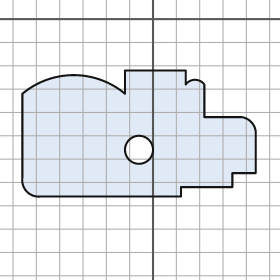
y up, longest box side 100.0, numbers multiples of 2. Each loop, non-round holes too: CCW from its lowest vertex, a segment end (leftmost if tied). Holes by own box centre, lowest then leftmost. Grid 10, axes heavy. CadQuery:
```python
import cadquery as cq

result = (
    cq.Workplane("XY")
    .moveTo(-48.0, -76.0)
    .lineTo(12.0, -76.0)
    .lineTo(12.0, -72.0)
    .lineTo(34.0, -72.0)
    .lineTo(34.0, -66.0)
    .lineTo(44.0, -66.0)
    .lineTo(44.0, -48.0)
    .threePointArc((42.0, -44.0), (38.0, -42.0))
    .lineTo(22.0, -42.0)
    .lineTo(22.0, -28.0)
    .threePointArc((18.0, -26.0), (14.0, -28.0))
    .lineTo(14.0, -22.0)
    .lineTo(-12.0, -22.0)
    .lineTo(-12.0, -32.0)
    .threePointArc((-34.0, -24.0), (-56.0, -32.0))
    .lineTo(-56.0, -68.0)
    .threePointArc((-54.0, -74.0), (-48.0, -76.0))
    .close()
    .moveTo(-6.0, -56.0)
    .circle(6.0)
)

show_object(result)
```